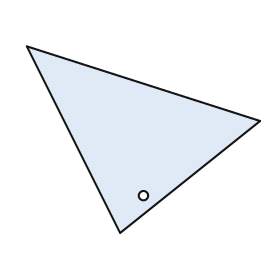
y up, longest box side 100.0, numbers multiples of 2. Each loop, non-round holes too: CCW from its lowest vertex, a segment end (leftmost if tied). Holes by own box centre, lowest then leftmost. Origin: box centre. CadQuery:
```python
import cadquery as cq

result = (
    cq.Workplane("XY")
    .moveTo(-10.0, -40.0)
    .lineTo(50.0, 8.0)
    .lineTo(-50.0, 40.0)
    .close()
    .moveTo(0.0, -24.0)
    .circle(2.0)
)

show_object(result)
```